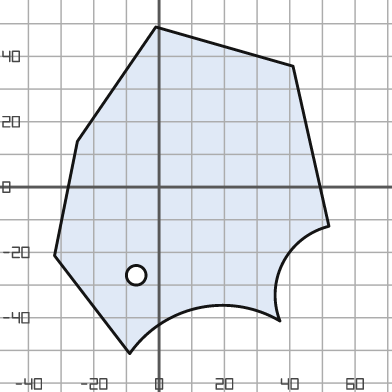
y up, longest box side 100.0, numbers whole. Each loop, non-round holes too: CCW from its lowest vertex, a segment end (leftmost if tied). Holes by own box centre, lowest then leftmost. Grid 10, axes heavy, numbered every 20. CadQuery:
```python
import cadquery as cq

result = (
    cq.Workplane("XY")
    .moveTo(-9.0, -51.0)
    .threePointArc((12.0, -37.0), (37.0, -41.0))
    .threePointArc((38.0, -23.0), (52.0, -12.0))
    .lineTo(41.0, 37.0)
    .lineTo(-1.0, 49.0)
    .lineTo(-25.0, 14.0)
    .lineTo(-32.0, -21.0)
    .close()
    .moveTo(-7.0, -27.0)
    .circle(3.0)
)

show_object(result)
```